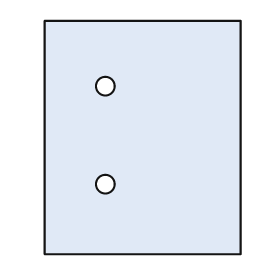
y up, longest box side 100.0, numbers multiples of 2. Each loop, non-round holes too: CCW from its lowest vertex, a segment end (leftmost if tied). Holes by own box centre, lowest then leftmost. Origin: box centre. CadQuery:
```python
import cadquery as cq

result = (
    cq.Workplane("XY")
    .moveTo(-42.0, -50.0)
    .lineTo(42.0, -50.0)
    .lineTo(42.0, 50.0)
    .lineTo(-42.0, 50.0)
    .close()
    .moveTo(-16.0, -20.0)
    .circle(4.0)
    .moveTo(-16.0, 22.0)
    .circle(4.0)
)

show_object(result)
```